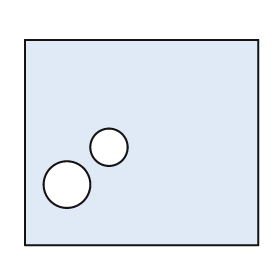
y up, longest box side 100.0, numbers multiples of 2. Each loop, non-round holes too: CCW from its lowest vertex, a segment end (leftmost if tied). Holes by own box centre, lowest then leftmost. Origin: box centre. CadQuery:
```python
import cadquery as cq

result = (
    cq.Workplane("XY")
    .moveTo(-50.0, -44.0)
    .lineTo(50.0, -44.0)
    .lineTo(50.0, 44.0)
    .lineTo(-50.0, 44.0)
    .close()
    .moveTo(-32.0, -18.0)
    .circle(10.0)
    .moveTo(-14.0, -2.0)
    .circle(8.0)
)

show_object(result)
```